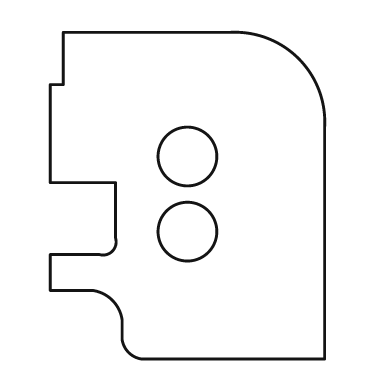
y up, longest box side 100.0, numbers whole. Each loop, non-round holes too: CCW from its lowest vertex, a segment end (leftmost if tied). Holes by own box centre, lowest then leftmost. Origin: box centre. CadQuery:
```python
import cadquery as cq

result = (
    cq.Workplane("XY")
    .moveTo(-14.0, -50.0)
    .lineTo(42.0, -50.0)
    .lineTo(42.0, 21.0)
    .threePointArc((34.0, 42.0), (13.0, 50.0))
    .lineTo(-38.0, 50.0)
    .lineTo(-38.0, 34.0)
    .lineTo(-42.0, 34.0)
    .lineTo(-42.0, 4.0)
    .lineTo(-22.0, 4.0)
    .lineTo(-22.0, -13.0)
    .threePointArc((-23.0, -17.0), (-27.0, -18.0))
    .lineTo(-42.0, -18.0)
    .lineTo(-42.0, -29.0)
    .lineTo(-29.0, -29.0)
    .threePointArc((-23.0, -32.0), (-20.0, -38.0))
    .lineTo(-20.0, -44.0)
    .threePointArc((-18.0, -48.0), (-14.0, -50.0))
    .close()
    .moveTo(0.0, -11.0)
    .circle(9.0)
    .moveTo(0.0, 12.0)
    .circle(9.0)
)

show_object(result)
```